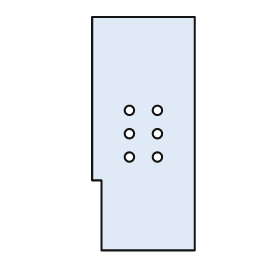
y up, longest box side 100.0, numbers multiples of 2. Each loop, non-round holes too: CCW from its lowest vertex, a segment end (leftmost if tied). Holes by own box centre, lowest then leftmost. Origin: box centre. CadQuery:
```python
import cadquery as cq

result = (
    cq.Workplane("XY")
    .moveTo(-18.0, -50.0)
    .lineTo(22.0, -50.0)
    .lineTo(22.0, 50.0)
    .lineTo(-22.0, 50.0)
    .lineTo(-22.0, -20.0)
    .lineTo(-18.0, -20.0)
    .close()
    .moveTo(-6.0, -10.0)
    .circle(2.0)
    .moveTo(6.0, -10.0)
    .circle(2.0)
    .moveTo(-6.0, 0.0)
    .circle(2.0)
    .moveTo(6.0, 0.0)
    .circle(2.0)
    .moveTo(-6.0, 10.0)
    .circle(2.0)
    .moveTo(6.0, 10.0)
    .circle(2.0)
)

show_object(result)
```